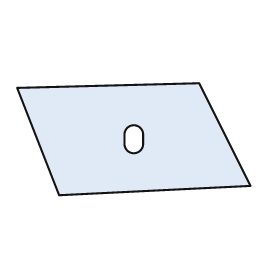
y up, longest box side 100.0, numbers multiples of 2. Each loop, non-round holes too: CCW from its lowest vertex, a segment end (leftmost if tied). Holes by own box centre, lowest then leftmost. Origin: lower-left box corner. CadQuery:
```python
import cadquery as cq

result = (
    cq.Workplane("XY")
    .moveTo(18.0, 0.0)
    .lineTo(100.0, 4.0)
    .lineTo(78.0, 48.0)
    .lineTo(0.0, 46.0)
    .close()
    .moveTo(46.0, 22.0)
    .threePointArc((50.0, 18.0), (54.0, 22.0))
    .lineTo(54.0, 26.0)
    .threePointArc((50.0, 30.0), (46.0, 26.0))
    .close()
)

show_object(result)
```